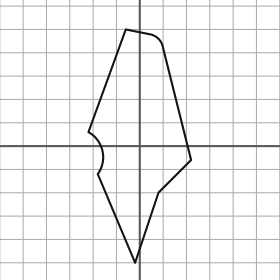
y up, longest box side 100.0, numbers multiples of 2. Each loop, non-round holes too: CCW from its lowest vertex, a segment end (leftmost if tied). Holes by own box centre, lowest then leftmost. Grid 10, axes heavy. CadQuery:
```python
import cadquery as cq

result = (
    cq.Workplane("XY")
    .moveTo(-2.0, -50.0)
    .lineTo(8.0, -20.0)
    .lineTo(22.0, -6.0)
    .lineTo(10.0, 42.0)
    .threePointArc((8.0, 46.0), (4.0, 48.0))
    .lineTo(-6.0, 50.0)
    .lineTo(-22.0, 6.0)
    .threePointArc((-16.0, -2.0), (-18.0, -12.0))
    .close()
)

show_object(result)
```